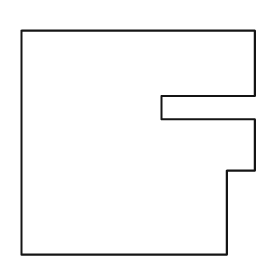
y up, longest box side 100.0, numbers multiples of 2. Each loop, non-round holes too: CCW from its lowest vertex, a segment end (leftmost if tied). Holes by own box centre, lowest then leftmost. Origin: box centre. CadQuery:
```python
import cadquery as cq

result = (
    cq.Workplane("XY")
    .moveTo(-50.0, -48.0)
    .lineTo(38.0, -48.0)
    .lineTo(38.0, -12.0)
    .lineTo(50.0, -12.0)
    .lineTo(50.0, 10.0)
    .lineTo(10.0, 10.0)
    .lineTo(10.0, 20.0)
    .lineTo(50.0, 20.0)
    .lineTo(50.0, 48.0)
    .lineTo(-50.0, 48.0)
    .close()
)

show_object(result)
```